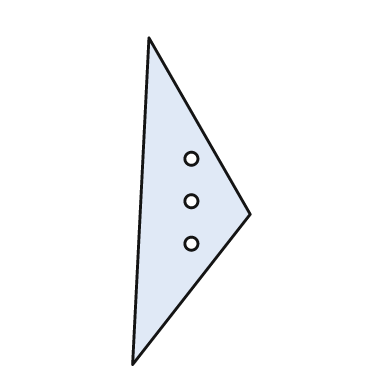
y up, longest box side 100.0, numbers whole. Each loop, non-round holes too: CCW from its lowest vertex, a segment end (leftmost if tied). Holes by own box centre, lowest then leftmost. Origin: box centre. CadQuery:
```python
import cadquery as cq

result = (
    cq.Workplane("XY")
    .moveTo(-18.0, -50.0)
    .lineTo(18.0, -4.0)
    .lineTo(-13.0, 50.0)
    .close()
    .moveTo(0.0, -13.0)
    .circle(2.0)
    .moveTo(0.0, 0.0)
    .circle(2.0)
    .moveTo(0.0, 13.0)
    .circle(2.0)
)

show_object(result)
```